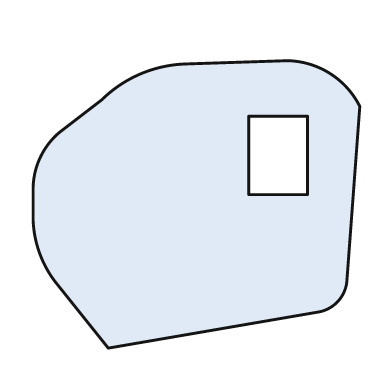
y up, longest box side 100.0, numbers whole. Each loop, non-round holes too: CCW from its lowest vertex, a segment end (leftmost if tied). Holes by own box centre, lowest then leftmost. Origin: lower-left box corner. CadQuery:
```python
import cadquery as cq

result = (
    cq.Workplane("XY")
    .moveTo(23.0, 0.0)
    .lineTo(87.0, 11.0)
    .threePointArc((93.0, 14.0), (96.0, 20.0))
    .lineTo(100.0, 74.0)
    .threePointArc((91.0, 84.0), (78.0, 88.0))
    .lineTo(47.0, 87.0)
    .threePointArc((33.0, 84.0), (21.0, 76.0))
    .lineTo(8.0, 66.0)
    .threePointArc((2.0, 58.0), (0.0, 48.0))
    .lineTo(0.0, 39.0)
    .threePointArc((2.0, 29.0), (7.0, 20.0))
    .close()
    .moveTo(66.0, 47.0)
    .lineTo(84.0, 47.0)
    .lineTo(84.0, 71.0)
    .lineTo(66.0, 71.0)
    .close()
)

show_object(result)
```